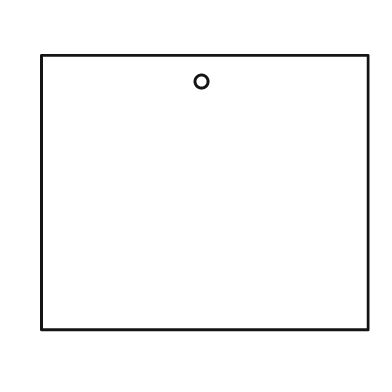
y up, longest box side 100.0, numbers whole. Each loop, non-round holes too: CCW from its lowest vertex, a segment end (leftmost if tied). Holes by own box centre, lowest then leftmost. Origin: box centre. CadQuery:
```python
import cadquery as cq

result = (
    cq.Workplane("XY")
    .moveTo(-50.0, -42.0)
    .lineTo(50.0, -42.0)
    .lineTo(50.0, 42.0)
    .lineTo(-50.0, 42.0)
    .close()
    .moveTo(-1.0, 34.0)
    .circle(2.0)
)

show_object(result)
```